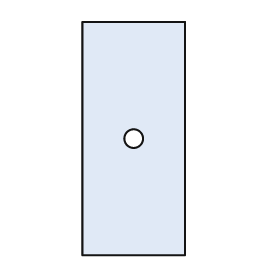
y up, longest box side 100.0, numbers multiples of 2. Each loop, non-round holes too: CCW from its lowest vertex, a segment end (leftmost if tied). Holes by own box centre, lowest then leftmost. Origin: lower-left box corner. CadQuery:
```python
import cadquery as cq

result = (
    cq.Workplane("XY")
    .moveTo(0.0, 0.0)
    .lineTo(44.0, 0.0)
    .lineTo(44.0, 100.0)
    .lineTo(0.0, 100.0)
    .close()
    .moveTo(22.0, 50.0)
    .circle(4.0)
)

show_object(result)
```